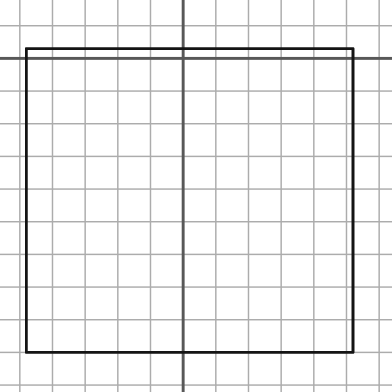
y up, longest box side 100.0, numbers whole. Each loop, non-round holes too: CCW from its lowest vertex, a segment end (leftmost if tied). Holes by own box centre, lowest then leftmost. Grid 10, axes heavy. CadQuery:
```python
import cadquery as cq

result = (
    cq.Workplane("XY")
    .moveTo(-48.0, -90.0)
    .lineTo(52.0, -90.0)
    .lineTo(52.0, 3.0)
    .lineTo(-48.0, 3.0)
    .close()
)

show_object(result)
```